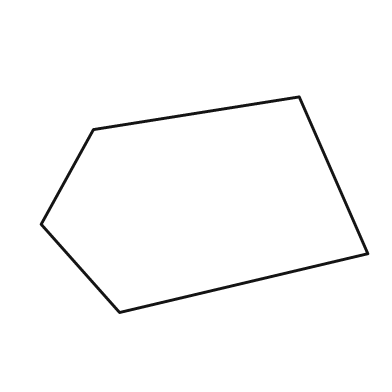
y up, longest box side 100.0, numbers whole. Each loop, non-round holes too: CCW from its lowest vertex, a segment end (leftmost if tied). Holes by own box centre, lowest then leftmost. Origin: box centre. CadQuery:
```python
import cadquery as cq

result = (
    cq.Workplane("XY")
    .moveTo(-26.0, -33.0)
    .lineTo(50.0, -15.0)
    .lineTo(29.0, 33.0)
    .lineTo(-34.0, 23.0)
    .lineTo(-50.0, -6.0)
    .close()
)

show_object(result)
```